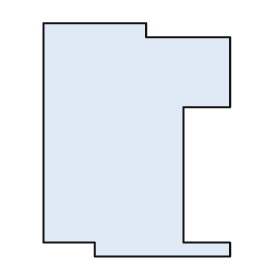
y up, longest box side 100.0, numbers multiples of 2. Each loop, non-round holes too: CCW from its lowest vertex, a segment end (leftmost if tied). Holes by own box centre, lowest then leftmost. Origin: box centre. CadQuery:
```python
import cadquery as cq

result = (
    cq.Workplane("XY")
    .moveTo(-18.0, -50.0)
    .lineTo(40.0, -50.0)
    .lineTo(40.0, -44.0)
    .lineTo(20.0, -44.0)
    .lineTo(20.0, 14.0)
    .lineTo(40.0, 14.0)
    .lineTo(40.0, 44.0)
    .lineTo(4.0, 44.0)
    .lineTo(4.0, 50.0)
    .lineTo(-40.0, 50.0)
    .lineTo(-40.0, -44.0)
    .lineTo(-18.0, -44.0)
    .close()
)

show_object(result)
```